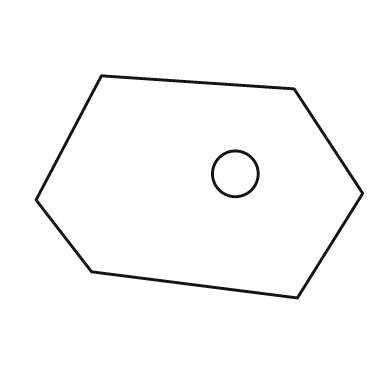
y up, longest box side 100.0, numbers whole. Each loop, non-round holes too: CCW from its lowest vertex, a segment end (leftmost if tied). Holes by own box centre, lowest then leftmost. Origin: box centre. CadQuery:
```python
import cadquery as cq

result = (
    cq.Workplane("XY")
    .moveTo(30.0, -34.0)
    .lineTo(50.0, -2.0)
    .lineTo(29.0, 30.0)
    .lineTo(-30.0, 34.0)
    .lineTo(-50.0, -4.0)
    .lineTo(-33.0, -26.0)
    .close()
    .moveTo(11.0, 4.0)
    .circle(7.0)
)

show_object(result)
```